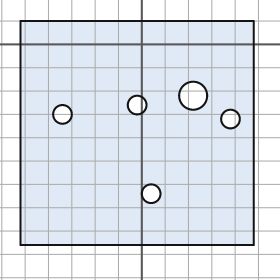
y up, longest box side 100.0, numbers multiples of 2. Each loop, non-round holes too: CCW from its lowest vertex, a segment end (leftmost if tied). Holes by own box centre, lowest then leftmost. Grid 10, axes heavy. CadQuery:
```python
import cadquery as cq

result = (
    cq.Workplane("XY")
    .moveTo(-52.0, -86.0)
    .lineTo(48.0, -86.0)
    .lineTo(48.0, 10.0)
    .lineTo(-52.0, 10.0)
    .close()
    .moveTo(4.0, -64.0)
    .circle(4.0)
    .moveTo(38.0, -32.0)
    .circle(4.0)
    .moveTo(-34.0, -30.0)
    .circle(4.0)
    .moveTo(-2.0, -26.0)
    .circle(4.0)
    .moveTo(22.0, -22.0)
    .circle(6.0)
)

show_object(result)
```